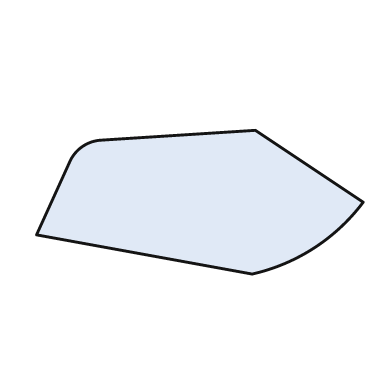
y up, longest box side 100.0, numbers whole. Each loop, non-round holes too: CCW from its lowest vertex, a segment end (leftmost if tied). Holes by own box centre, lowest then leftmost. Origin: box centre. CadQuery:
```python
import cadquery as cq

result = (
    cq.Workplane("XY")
    .moveTo(16.0, -22.0)
    .threePointArc((35.0, -14.0), (50.0, 0.0))
    .lineTo(17.0, 22.0)
    .lineTo(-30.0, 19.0)
    .threePointArc((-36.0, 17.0), (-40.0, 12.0))
    .lineTo(-50.0, -10.0)
    .close()
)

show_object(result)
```